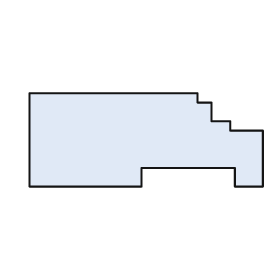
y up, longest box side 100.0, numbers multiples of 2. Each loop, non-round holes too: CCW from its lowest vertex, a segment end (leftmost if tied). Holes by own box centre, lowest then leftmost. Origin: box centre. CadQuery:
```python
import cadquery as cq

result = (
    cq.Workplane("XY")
    .moveTo(-50.0, -20.0)
    .lineTo(-2.0, -20.0)
    .lineTo(-2.0, -12.0)
    .lineTo(38.0, -12.0)
    .lineTo(38.0, -20.0)
    .lineTo(50.0, -20.0)
    .lineTo(50.0, 4.0)
    .lineTo(36.0, 4.0)
    .lineTo(36.0, 8.0)
    .lineTo(28.0, 8.0)
    .lineTo(28.0, 16.0)
    .lineTo(22.0, 16.0)
    .lineTo(22.0, 20.0)
    .lineTo(-50.0, 20.0)
    .close()
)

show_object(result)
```